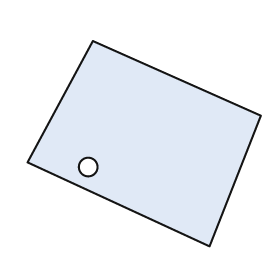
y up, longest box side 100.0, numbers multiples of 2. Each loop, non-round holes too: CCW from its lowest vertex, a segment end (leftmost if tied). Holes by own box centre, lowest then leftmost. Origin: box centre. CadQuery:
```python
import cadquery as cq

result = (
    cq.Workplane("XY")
    .moveTo(28.0, -44.0)
    .lineTo(50.0, 12.0)
    .lineTo(-22.0, 44.0)
    .lineTo(-50.0, -8.0)
    .close()
    .moveTo(-24.0, -10.0)
    .circle(4.0)
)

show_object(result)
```